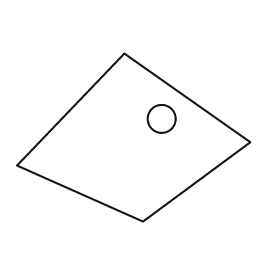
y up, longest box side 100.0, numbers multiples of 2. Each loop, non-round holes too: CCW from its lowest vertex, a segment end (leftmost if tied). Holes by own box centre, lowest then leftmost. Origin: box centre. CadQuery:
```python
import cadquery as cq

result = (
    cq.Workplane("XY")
    .moveTo(4.0, -36.0)
    .lineTo(50.0, -2.0)
    .lineTo(-4.0, 36.0)
    .lineTo(-50.0, -12.0)
    .close()
    .moveTo(12.0, 8.0)
    .circle(6.0)
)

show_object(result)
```